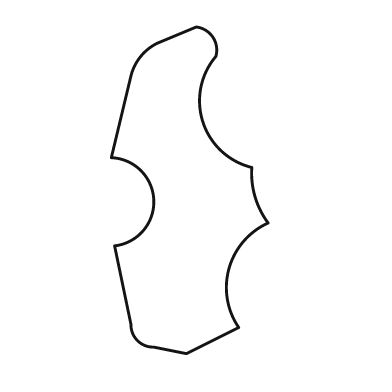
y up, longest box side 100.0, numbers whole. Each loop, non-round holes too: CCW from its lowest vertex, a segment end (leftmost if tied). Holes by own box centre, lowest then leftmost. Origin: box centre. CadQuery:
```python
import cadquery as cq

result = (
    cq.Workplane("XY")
    .moveTo(-1.0, -50.0)
    .lineTo(15.0, -42.0)
    .threePointArc((12.0, -24.0), (24.0, -10.0))
    .threePointArc((20.0, -2.0), (19.0, 7.0))
    .threePointArc((4.0, 21.0), (8.0, 41.0))
    .threePointArc((7.0, 47.0), (2.0, 50.0))
    .lineTo(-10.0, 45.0)
    .threePointArc((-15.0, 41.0), (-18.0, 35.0))
    .lineTo(-24.0, 10.0)
    .threePointArc((-11.0, -3.0), (-23.0, -17.0))
    .lineTo(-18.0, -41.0)
    .threePointArc((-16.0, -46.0), (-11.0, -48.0))
    .close()
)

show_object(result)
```